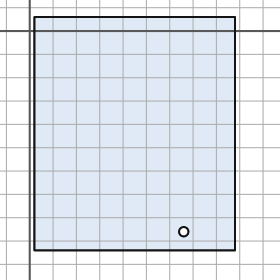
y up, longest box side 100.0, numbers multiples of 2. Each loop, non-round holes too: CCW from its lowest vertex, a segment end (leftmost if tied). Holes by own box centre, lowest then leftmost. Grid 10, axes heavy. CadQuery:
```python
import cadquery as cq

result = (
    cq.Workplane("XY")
    .moveTo(2.0, -94.0)
    .lineTo(88.0, -94.0)
    .lineTo(88.0, 6.0)
    .lineTo(2.0, 6.0)
    .close()
    .moveTo(66.0, -86.0)
    .circle(2.0)
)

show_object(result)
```